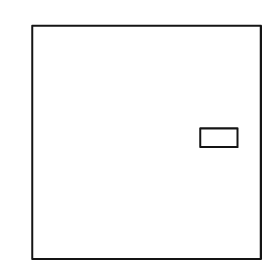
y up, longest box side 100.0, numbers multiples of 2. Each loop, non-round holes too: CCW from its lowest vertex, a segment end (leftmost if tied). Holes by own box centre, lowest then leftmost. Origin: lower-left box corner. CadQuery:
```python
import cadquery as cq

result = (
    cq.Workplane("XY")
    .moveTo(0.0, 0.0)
    .lineTo(98.0, 0.0)
    .lineTo(98.0, 100.0)
    .lineTo(0.0, 100.0)
    .close()
    .moveTo(72.0, 48.0)
    .lineTo(88.0, 48.0)
    .lineTo(88.0, 56.0)
    .lineTo(72.0, 56.0)
    .close()
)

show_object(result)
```